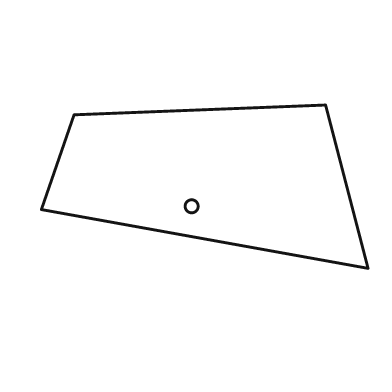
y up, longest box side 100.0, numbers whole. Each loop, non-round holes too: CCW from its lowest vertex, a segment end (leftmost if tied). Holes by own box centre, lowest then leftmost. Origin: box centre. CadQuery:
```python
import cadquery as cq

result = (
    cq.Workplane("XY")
    .moveTo(50.0, -25.0)
    .lineTo(37.0, 25.0)
    .lineTo(-40.0, 22.0)
    .lineTo(-50.0, -7.0)
    .close()
    .moveTo(-4.0, -6.0)
    .circle(2.0)
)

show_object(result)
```